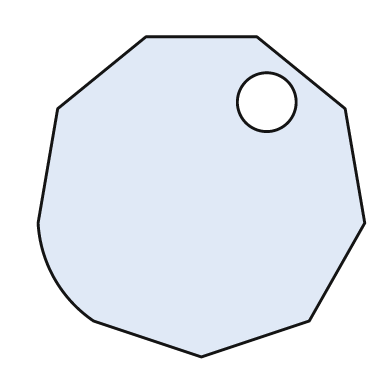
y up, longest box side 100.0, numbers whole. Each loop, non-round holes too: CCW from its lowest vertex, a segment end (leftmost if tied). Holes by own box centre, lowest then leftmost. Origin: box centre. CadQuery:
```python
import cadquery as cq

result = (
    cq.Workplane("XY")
    .moveTo(0.0, -49.0)
    .lineTo(33.0, -38.0)
    .lineTo(50.0, -8.0)
    .lineTo(44.0, 27.0)
    .lineTo(17.0, 49.0)
    .lineTo(-17.0, 49.0)
    .lineTo(-44.0, 27.0)
    .lineTo(-50.0, -8.0)
    .threePointArc((-45.0, -25.0), (-33.0, -38.0))
    .close()
    .moveTo(20.0, 29.0)
    .circle(9.0)
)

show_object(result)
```